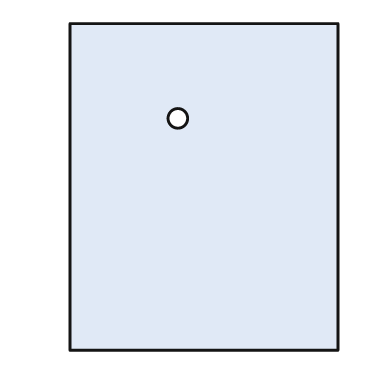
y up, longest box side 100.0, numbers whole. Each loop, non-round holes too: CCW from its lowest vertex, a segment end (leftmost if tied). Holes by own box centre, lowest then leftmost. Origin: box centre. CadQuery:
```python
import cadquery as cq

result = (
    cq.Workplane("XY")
    .moveTo(-41.0, -50.0)
    .lineTo(41.0, -50.0)
    .lineTo(41.0, 50.0)
    .lineTo(-41.0, 50.0)
    .close()
    .moveTo(-8.0, 21.0)
    .circle(3.0)
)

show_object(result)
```